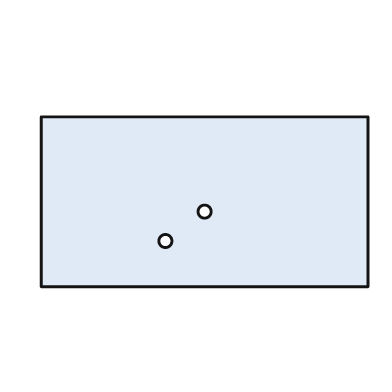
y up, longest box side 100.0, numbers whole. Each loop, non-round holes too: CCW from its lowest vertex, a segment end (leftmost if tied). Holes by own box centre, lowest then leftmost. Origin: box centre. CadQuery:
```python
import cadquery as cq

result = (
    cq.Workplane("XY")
    .moveTo(-50.0, -26.0)
    .lineTo(50.0, -26.0)
    .lineTo(50.0, 26.0)
    .lineTo(-50.0, 26.0)
    .close()
    .moveTo(-12.0, -12.0)
    .circle(2.0)
    .moveTo(0.0, -3.0)
    .circle(2.0)
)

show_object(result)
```